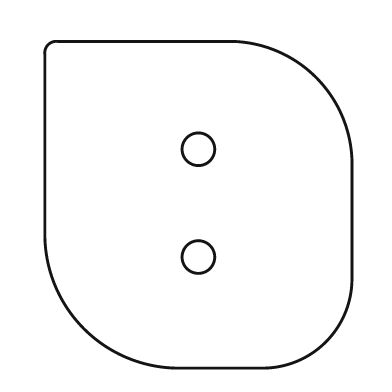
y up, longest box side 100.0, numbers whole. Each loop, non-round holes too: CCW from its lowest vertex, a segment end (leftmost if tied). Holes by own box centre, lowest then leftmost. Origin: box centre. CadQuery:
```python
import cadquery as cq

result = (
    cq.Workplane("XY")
    .moveTo(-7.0, -50.0)
    .lineTo(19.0, -50.0)
    .threePointArc((39.0, -42.0), (47.0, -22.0))
    .lineTo(47.0, 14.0)
    .threePointArc((36.0, 39.0), (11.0, 50.0))
    .lineTo(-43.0, 50.0)
    .threePointArc((-46.0, 49.0), (-47.0, 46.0))
    .lineTo(-47.0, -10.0)
    .threePointArc((-35.0, -38.0), (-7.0, -50.0))
    .close()
    .moveTo(0.0, -16.0)
    .circle(5.0)
    .moveTo(0.0, 17.0)
    .circle(5.0)
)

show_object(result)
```